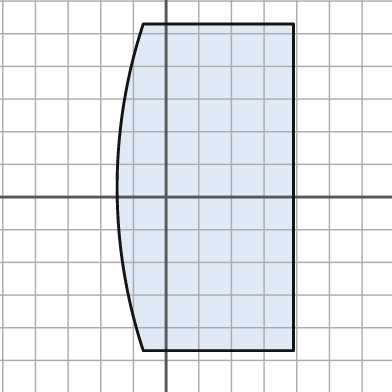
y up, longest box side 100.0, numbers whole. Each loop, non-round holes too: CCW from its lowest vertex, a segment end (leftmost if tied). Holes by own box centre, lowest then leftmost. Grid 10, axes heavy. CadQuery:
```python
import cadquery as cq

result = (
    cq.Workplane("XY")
    .moveTo(-7.0, -47.0)
    .lineTo(39.0, -47.0)
    .lineTo(39.0, 53.0)
    .lineTo(-7.0, 53.0)
    .threePointArc((-15.0, 3.0), (-7.0, -47.0))
    .close()
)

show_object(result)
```